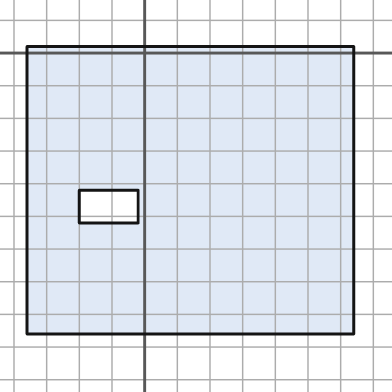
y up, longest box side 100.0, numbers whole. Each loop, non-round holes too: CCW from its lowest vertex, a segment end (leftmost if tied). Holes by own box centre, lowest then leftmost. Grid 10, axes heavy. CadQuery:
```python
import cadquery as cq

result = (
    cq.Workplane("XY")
    .moveTo(-36.0, -86.0)
    .lineTo(64.0, -86.0)
    .lineTo(64.0, 2.0)
    .lineTo(-36.0, 2.0)
    .close()
    .moveTo(-20.0, -52.0)
    .lineTo(-2.0, -52.0)
    .lineTo(-2.0, -42.0)
    .lineTo(-20.0, -42.0)
    .close()
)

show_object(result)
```